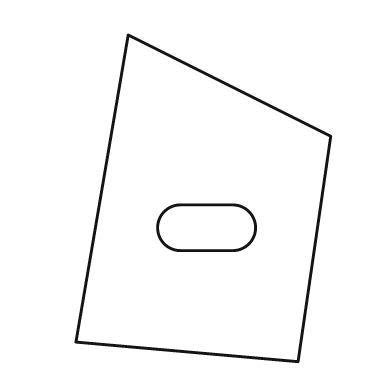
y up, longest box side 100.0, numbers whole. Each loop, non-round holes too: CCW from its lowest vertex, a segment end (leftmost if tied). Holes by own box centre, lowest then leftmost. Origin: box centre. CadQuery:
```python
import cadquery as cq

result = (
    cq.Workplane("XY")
    .moveTo(29.0, -50.0)
    .lineTo(39.0, 19.0)
    .lineTo(-23.0, 50.0)
    .lineTo(-39.0, -44.0)
    .close()
    .moveTo(-7.0, -16.0)
    .lineTo(9.0, -16.0)
    .threePointArc((16.0, -9.0), (9.0, -2.0))
    .lineTo(-7.0, -2.0)
    .threePointArc((-14.0, -9.0), (-7.0, -16.0))
    .close()
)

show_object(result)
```